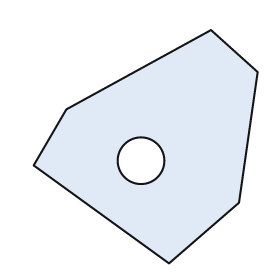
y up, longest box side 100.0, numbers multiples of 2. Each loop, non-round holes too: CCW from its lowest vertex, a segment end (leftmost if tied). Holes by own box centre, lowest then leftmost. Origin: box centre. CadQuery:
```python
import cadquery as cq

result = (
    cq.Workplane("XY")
    .moveTo(10.0, -50.0)
    .lineTo(40.0, -24.0)
    .lineTo(48.0, 32.0)
    .lineTo(28.0, 50.0)
    .lineTo(-34.0, 16.0)
    .lineTo(-48.0, -8.0)
    .close()
    .moveTo(-2.0, -6.0)
    .circle(10.0)
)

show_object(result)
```